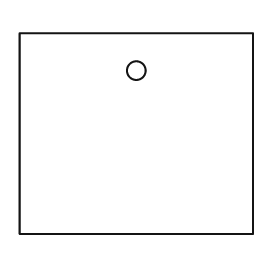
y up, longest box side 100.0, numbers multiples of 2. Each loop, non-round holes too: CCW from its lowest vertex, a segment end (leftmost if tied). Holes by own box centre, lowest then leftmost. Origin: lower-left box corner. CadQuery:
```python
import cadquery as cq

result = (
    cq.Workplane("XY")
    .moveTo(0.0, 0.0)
    .lineTo(100.0, 0.0)
    .lineTo(100.0, 86.0)
    .lineTo(0.0, 86.0)
    .close()
    .moveTo(50.0, 70.0)
    .circle(4.0)
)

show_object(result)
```